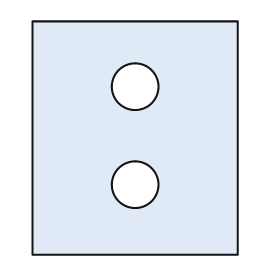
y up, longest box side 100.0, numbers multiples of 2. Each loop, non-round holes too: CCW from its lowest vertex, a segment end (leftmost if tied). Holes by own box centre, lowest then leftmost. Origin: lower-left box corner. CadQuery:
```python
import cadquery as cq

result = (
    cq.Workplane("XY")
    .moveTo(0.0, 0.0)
    .lineTo(88.0, 0.0)
    .lineTo(88.0, 100.0)
    .lineTo(0.0, 100.0)
    .close()
    .moveTo(44.0, 30.0)
    .circle(10.0)
    .moveTo(44.0, 72.0)
    .circle(10.0)
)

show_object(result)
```